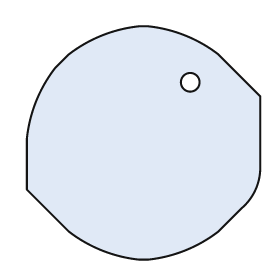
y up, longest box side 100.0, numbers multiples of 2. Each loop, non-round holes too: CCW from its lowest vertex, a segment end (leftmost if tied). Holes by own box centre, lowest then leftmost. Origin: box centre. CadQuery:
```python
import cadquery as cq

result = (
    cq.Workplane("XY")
    .moveTo(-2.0, -50.0)
    .lineTo(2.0, -50.0)
    .threePointArc((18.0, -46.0), (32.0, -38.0))
    .lineTo(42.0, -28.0)
    .threePointArc((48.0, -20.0), (50.0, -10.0))
    .lineTo(50.0, 20.0)
    .lineTo(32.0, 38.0)
    .threePointArc((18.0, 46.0), (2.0, 50.0))
    .lineTo(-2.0, 50.0)
    .threePointArc((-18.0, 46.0), (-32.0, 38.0))
    .lineTo(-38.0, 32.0)
    .threePointArc((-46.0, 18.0), (-50.0, 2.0))
    .lineTo(-50.0, -20.0)
    .lineTo(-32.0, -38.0)
    .threePointArc((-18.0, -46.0), (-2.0, -50.0))
    .close()
    .moveTo(20.0, 26.0)
    .circle(4.0)
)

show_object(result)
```